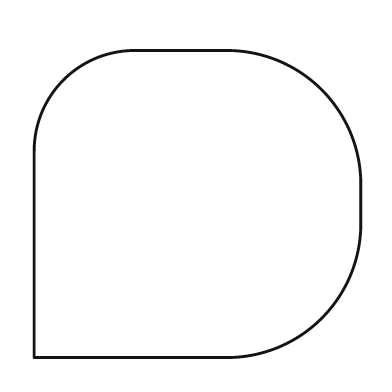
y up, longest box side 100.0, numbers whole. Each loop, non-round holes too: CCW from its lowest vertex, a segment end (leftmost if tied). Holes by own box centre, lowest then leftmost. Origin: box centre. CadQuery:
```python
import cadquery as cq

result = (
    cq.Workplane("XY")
    .moveTo(-50.0, -47.0)
    .lineTo(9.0, -47.0)
    .threePointArc((38.0, -35.0), (50.0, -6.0))
    .lineTo(50.0, 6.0)
    .threePointArc((38.0, 35.0), (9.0, 47.0))
    .lineTo(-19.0, 47.0)
    .threePointArc((-41.0, 38.0), (-50.0, 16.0))
    .close()
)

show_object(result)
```